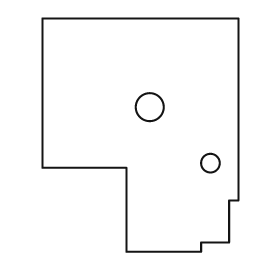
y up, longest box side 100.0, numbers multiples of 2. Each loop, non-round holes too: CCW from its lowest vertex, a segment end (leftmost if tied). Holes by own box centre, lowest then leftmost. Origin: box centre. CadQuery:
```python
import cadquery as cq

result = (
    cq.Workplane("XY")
    .moveTo(-6.0, -50.0)
    .lineTo(26.0, -50.0)
    .lineTo(26.0, -46.0)
    .lineTo(38.0, -46.0)
    .lineTo(38.0, -28.0)
    .lineTo(42.0, -28.0)
    .lineTo(42.0, 50.0)
    .lineTo(-42.0, 50.0)
    .lineTo(-42.0, -14.0)
    .lineTo(-6.0, -14.0)
    .close()
    .moveTo(30.0, -12.0)
    .circle(4.0)
    .moveTo(4.0, 12.0)
    .circle(6.0)
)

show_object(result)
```